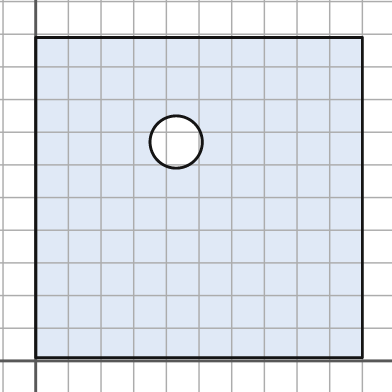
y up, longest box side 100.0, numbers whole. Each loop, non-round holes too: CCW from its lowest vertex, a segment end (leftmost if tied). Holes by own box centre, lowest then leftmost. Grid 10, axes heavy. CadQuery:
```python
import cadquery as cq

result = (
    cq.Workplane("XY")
    .moveTo(0.0, 1.0)
    .lineTo(100.0, 1.0)
    .lineTo(100.0, 99.0)
    .lineTo(0.0, 99.0)
    .close()
    .moveTo(43.0, 67.0)
    .circle(8.0)
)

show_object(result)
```